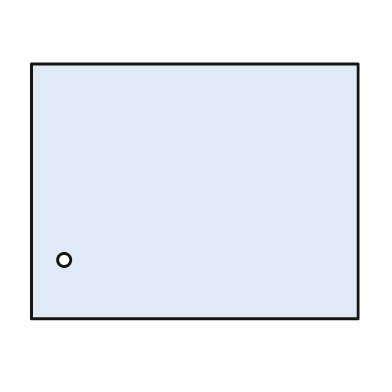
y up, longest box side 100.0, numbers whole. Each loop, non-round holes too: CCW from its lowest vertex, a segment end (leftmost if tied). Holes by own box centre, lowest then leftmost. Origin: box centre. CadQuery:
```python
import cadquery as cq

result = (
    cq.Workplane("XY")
    .moveTo(-50.0, -39.0)
    .lineTo(50.0, -39.0)
    .lineTo(50.0, 39.0)
    .lineTo(-50.0, 39.0)
    .close()
    .moveTo(-40.0, -21.0)
    .circle(2.0)
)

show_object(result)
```